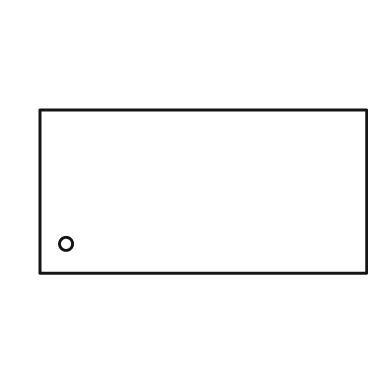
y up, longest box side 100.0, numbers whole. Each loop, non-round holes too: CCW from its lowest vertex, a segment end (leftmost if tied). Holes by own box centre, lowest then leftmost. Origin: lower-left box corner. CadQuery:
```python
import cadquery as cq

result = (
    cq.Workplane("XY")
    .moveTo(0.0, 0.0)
    .lineTo(100.0, 0.0)
    .lineTo(100.0, 50.0)
    .lineTo(0.0, 50.0)
    .close()
    .moveTo(8.0, 9.0)
    .circle(2.0)
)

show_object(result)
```